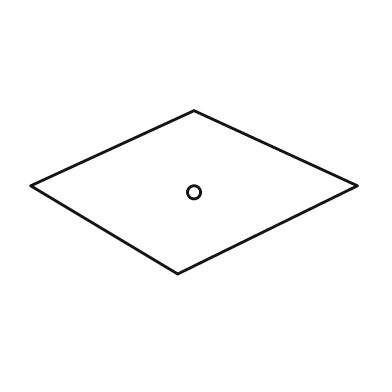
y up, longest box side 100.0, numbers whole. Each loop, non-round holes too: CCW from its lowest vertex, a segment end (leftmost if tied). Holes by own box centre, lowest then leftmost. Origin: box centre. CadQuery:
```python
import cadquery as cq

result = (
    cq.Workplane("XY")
    .moveTo(-5.0, -25.0)
    .lineTo(50.0, 2.0)
    .lineTo(0.0, 25.0)
    .lineTo(-50.0, 2.0)
    .close()
    .moveTo(0.0, 0.0)
    .circle(2.0)
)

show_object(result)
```